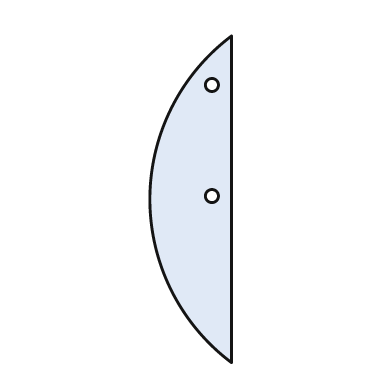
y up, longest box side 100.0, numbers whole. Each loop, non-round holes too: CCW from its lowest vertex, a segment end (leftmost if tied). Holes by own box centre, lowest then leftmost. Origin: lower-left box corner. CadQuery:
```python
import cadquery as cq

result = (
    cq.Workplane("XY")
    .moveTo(25.0, 0.0)
    .lineTo(25.0, 100.0)
    .threePointArc((0.0, 50.0), (25.0, 0.0))
    .close()
    .moveTo(19.0, 51.0)
    .circle(2.0)
    .moveTo(19.0, 85.0)
    .circle(2.0)
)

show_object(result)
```